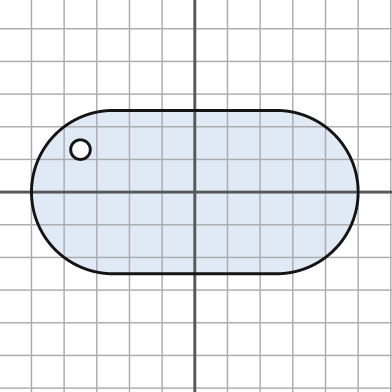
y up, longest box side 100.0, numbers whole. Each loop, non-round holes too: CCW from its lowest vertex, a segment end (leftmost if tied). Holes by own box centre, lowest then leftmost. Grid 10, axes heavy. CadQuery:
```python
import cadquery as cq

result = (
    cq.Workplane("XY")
    .moveTo(-25.0, -25.0)
    .lineTo(25.0, -25.0)
    .threePointArc((50.0, 0.0), (25.0, 25.0))
    .lineTo(-25.0, 25.0)
    .threePointArc((-50.0, 0.0), (-25.0, -25.0))
    .close()
    .moveTo(-35.0, 13.0)
    .circle(3.0)
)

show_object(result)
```